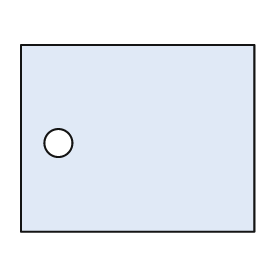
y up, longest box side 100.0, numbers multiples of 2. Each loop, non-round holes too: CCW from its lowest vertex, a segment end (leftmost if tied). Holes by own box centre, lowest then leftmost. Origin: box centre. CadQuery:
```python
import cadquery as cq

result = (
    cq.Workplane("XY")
    .moveTo(-50.0, -40.0)
    .lineTo(50.0, -40.0)
    .lineTo(50.0, 40.0)
    .lineTo(-50.0, 40.0)
    .close()
    .moveTo(-34.0, -2.0)
    .circle(6.0)
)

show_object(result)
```